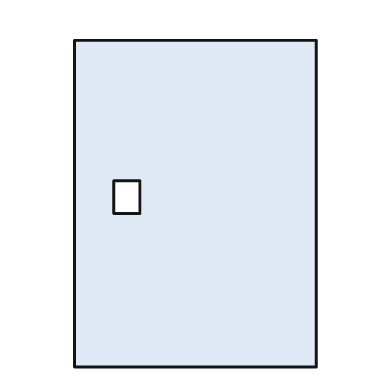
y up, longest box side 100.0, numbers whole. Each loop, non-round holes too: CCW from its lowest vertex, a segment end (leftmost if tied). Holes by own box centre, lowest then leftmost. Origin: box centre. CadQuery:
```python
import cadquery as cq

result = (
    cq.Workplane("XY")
    .moveTo(-37.0, -50.0)
    .lineTo(37.0, -50.0)
    .lineTo(37.0, 50.0)
    .lineTo(-37.0, 50.0)
    .close()
    .moveTo(-25.0, -3.0)
    .lineTo(-17.0, -3.0)
    .lineTo(-17.0, 7.0)
    .lineTo(-25.0, 7.0)
    .close()
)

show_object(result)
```